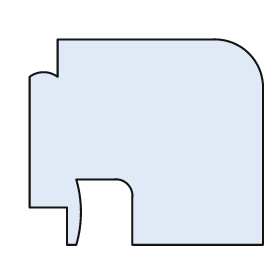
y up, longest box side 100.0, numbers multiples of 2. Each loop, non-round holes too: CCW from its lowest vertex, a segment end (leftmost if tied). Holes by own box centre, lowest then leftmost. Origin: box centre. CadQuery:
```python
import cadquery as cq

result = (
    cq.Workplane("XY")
    .moveTo(-34.0, -44.0)
    .lineTo(-30.0, -44.0)
    .threePointArc((-28.0, -30.0), (-30.0, -16.0))
    .lineTo(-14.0, -16.0)
    .threePointArc((-8.0, -18.0), (-6.0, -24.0))
    .lineTo(-6.0, -44.0)
    .lineTo(50.0, -44.0)
    .lineTo(50.0, 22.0)
    .threePointArc((44.0, 38.0), (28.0, 44.0))
    .lineTo(-38.0, 44.0)
    .lineTo(-38.0, 28.0)
    .threePointArc((-44.0, 30.0), (-50.0, 28.0))
    .lineTo(-50.0, -28.0)
    .lineTo(-34.0, -28.0)
    .close()
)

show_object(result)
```